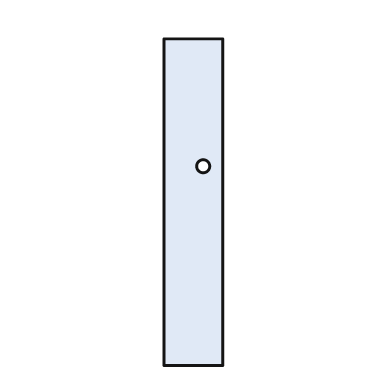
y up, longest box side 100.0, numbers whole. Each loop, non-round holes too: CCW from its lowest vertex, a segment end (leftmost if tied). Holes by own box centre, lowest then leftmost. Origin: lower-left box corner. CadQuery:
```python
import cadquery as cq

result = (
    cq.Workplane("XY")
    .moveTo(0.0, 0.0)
    .lineTo(18.0, 0.0)
    .lineTo(18.0, 100.0)
    .lineTo(0.0, 100.0)
    .close()
    .moveTo(12.0, 61.0)
    .circle(2.0)
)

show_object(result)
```